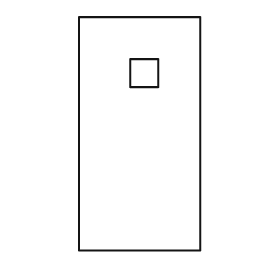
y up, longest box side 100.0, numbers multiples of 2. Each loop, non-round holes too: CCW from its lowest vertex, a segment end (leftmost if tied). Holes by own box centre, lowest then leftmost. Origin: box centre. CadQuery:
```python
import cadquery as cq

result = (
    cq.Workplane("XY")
    .moveTo(-26.0, -50.0)
    .lineTo(26.0, -50.0)
    .lineTo(26.0, 50.0)
    .lineTo(-26.0, 50.0)
    .close()
    .moveTo(-4.0, 20.0)
    .lineTo(8.0, 20.0)
    .lineTo(8.0, 32.0)
    .lineTo(-4.0, 32.0)
    .close()
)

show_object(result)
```